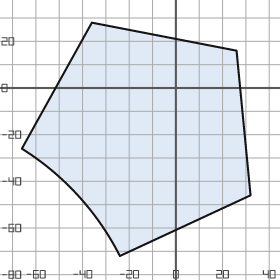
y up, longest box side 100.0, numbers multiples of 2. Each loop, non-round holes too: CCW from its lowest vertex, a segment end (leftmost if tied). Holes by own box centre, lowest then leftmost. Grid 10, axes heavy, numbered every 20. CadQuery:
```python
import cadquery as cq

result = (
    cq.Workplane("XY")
    .moveTo(-24.0, -72.0)
    .lineTo(32.0, -46.0)
    .lineTo(26.0, 16.0)
    .lineTo(-36.0, 28.0)
    .lineTo(-66.0, -26.0)
    .threePointArc((-42.0, -46.0), (-24.0, -72.0))
    .close()
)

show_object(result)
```